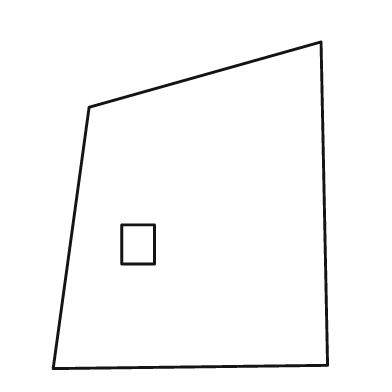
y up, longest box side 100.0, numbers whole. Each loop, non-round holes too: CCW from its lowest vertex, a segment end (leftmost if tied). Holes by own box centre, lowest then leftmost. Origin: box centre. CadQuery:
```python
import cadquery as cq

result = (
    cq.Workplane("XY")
    .moveTo(-42.0, -50.0)
    .lineTo(42.0, -49.0)
    .lineTo(40.0, 50.0)
    .lineTo(-31.0, 30.0)
    .close()
    .moveTo(-21.0, -18.0)
    .lineTo(-11.0, -18.0)
    .lineTo(-11.0, -6.0)
    .lineTo(-21.0, -6.0)
    .close()
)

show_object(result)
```